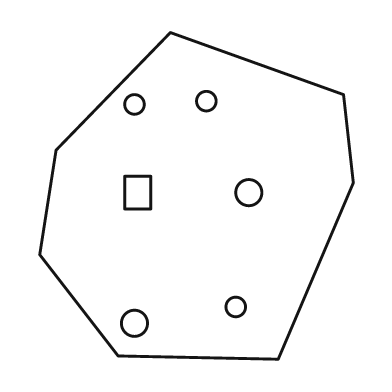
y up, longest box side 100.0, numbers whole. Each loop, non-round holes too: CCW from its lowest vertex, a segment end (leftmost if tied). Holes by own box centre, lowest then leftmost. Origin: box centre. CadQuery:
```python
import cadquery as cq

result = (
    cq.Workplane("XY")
    .moveTo(25.0, -50.0)
    .lineTo(48.0, 4.0)
    .lineTo(45.0, 31.0)
    .lineTo(-8.0, 50.0)
    .lineTo(-43.0, 14.0)
    .lineTo(-48.0, -18.0)
    .lineTo(-24.0, -49.0)
    .close()
    .moveTo(-19.0, -39.0)
    .circle(4.0)
    .moveTo(12.0, -34.0)
    .circle(3.0)
    .moveTo(-22.0, -4.0)
    .lineTo(-14.0, -4.0)
    .lineTo(-14.0, 6.0)
    .lineTo(-22.0, 6.0)
    .close()
    .moveTo(16.0, 1.0)
    .circle(4.0)
    .moveTo(-19.0, 28.0)
    .circle(3.0)
    .moveTo(3.0, 29.0)
    .circle(3.0)
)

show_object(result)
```